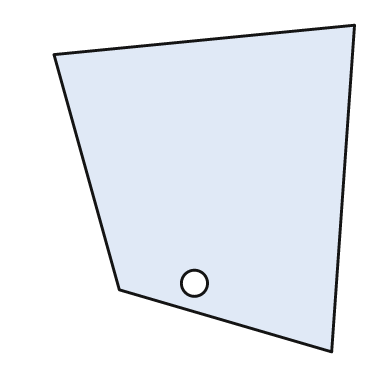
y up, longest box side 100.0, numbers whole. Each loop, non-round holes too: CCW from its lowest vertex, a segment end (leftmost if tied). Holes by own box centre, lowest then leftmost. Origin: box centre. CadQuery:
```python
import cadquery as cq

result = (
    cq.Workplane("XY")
    .moveTo(39.0, -50.0)
    .lineTo(46.0, 50.0)
    .lineTo(-46.0, 41.0)
    .lineTo(-26.0, -31.0)
    .close()
    .moveTo(-3.0, -29.0)
    .circle(4.0)
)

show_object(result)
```